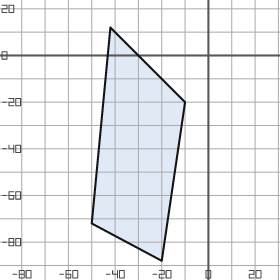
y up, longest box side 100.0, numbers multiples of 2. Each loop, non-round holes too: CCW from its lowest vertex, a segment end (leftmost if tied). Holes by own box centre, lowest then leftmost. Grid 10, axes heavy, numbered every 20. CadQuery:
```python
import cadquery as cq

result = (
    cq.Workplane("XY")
    .moveTo(-20.0, -88.0)
    .lineTo(-10.0, -20.0)
    .lineTo(-42.0, 12.0)
    .lineTo(-50.0, -72.0)
    .close()
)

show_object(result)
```